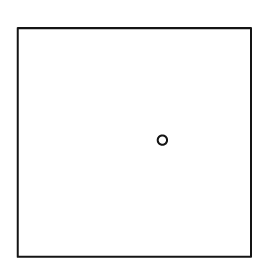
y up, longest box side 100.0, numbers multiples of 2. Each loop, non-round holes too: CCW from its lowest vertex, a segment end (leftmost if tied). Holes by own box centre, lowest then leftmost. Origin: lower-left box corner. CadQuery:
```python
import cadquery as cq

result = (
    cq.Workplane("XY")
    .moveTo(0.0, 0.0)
    .lineTo(100.0, 0.0)
    .lineTo(100.0, 98.0)
    .lineTo(0.0, 98.0)
    .close()
    .moveTo(62.0, 50.0)
    .circle(2.0)
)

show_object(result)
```